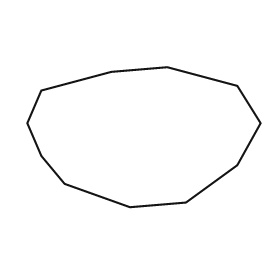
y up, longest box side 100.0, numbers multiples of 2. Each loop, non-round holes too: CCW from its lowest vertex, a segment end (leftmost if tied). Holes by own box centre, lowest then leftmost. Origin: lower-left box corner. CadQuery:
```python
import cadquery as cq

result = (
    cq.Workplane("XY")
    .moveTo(44.0, 0.0)
    .lineTo(68.0, 2.0)
    .lineTo(90.0, 18.0)
    .lineTo(100.0, 36.0)
    .lineTo(90.0, 52.0)
    .lineTo(60.0, 60.0)
    .lineTo(36.0, 58.0)
    .lineTo(6.0, 50.0)
    .lineTo(0.0, 36.0)
    .lineTo(6.0, 22.0)
    .lineTo(16.0, 10.0)
    .close()
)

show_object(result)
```